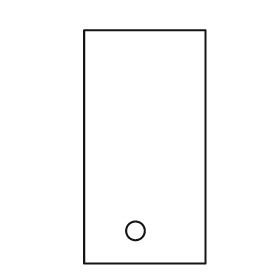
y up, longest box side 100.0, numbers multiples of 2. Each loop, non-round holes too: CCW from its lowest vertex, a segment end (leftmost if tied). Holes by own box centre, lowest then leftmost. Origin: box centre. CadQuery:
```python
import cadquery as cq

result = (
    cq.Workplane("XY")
    .moveTo(-26.0, -50.0)
    .lineTo(26.0, -50.0)
    .lineTo(26.0, 50.0)
    .lineTo(-26.0, 50.0)
    .close()
    .moveTo(-4.0, -36.0)
    .circle(4.0)
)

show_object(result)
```